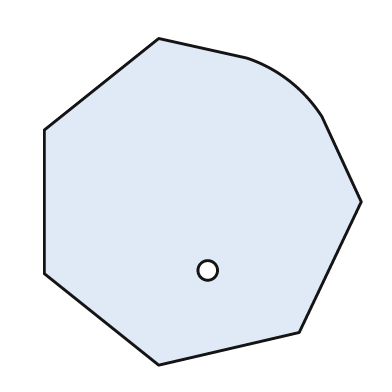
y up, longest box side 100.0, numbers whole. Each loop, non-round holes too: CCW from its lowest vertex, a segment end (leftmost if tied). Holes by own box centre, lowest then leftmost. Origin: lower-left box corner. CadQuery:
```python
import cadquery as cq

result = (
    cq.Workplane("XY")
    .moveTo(35.0, 0.0)
    .lineTo(78.0, 10.0)
    .lineTo(97.0, 50.0)
    .lineTo(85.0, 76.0)
    .threePointArc((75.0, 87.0), (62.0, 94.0))
    .lineTo(35.0, 100.0)
    .lineTo(0.0, 72.0)
    .lineTo(0.0, 28.0)
    .close()
    .moveTo(50.0, 29.0)
    .circle(3.0)
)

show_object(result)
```